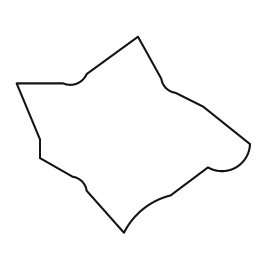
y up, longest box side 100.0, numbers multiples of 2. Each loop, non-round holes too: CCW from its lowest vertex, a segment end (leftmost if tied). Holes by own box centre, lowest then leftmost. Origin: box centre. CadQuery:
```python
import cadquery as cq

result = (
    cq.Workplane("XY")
    .moveTo(-4.0, -42.0)
    .threePointArc((4.0, -32.0), (16.0, -26.0))
    .lineTo(32.0, -14.0)
    .threePointArc((44.0, -14.0), (50.0, -4.0))
    .lineTo(30.0, 12.0)
    .lineTo(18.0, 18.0)
    .threePointArc((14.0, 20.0), (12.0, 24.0))
    .lineTo(2.0, 42.0)
    .lineTo(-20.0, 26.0)
    .threePointArc((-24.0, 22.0), (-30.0, 22.0))
    .lineTo(-50.0, 22.0)
    .lineTo(-40.0, -2.0)
    .lineTo(-40.0, -10.0)
    .lineTo(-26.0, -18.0)
    .threePointArc((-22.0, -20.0), (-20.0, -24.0))
    .close()
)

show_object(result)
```